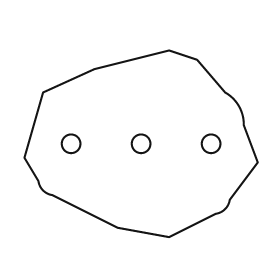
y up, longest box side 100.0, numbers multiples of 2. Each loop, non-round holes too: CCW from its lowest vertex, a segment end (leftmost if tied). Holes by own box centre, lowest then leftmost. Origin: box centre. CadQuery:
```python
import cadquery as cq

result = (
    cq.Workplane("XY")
    .moveTo(12.0, -40.0)
    .lineTo(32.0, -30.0)
    .threePointArc((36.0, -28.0), (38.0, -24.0))
    .lineTo(50.0, -8.0)
    .lineTo(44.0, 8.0)
    .threePointArc((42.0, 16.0), (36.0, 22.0))
    .lineTo(24.0, 36.0)
    .lineTo(12.0, 40.0)
    .lineTo(-20.0, 32.0)
    .lineTo(-42.0, 22.0)
    .lineTo(-50.0, -6.0)
    .lineTo(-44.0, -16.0)
    .threePointArc((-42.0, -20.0), (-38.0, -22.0))
    .lineTo(-10.0, -36.0)
    .close()
    .moveTo(-30.0, 0.0)
    .circle(4.0)
    .moveTo(0.0, 0.0)
    .circle(4.0)
    .moveTo(30.0, 0.0)
    .circle(4.0)
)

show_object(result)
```